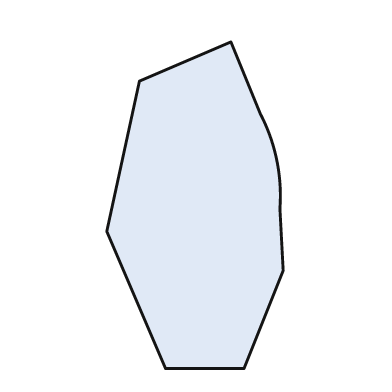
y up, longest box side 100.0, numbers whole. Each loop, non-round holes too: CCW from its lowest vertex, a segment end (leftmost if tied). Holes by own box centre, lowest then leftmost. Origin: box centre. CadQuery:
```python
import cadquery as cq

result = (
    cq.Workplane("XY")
    .moveTo(-9.0, -50.0)
    .lineTo(15.0, -50.0)
    .lineTo(27.0, -20.0)
    .lineTo(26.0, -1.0)
    .threePointArc((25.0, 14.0), (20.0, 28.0))
    .lineTo(11.0, 50.0)
    .lineTo(-17.0, 38.0)
    .lineTo(-27.0, -8.0)
    .close()
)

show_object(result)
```